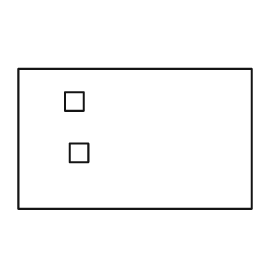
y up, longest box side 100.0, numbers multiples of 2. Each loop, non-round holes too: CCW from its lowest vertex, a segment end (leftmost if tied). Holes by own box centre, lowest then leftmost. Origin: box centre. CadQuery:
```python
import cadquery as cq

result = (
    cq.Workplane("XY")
    .moveTo(-50.0, -30.0)
    .lineTo(50.0, -30.0)
    .lineTo(50.0, 30.0)
    .lineTo(-50.0, 30.0)
    .close()
    .moveTo(-28.0, -10.0)
    .lineTo(-20.0, -10.0)
    .lineTo(-20.0, -2.0)
    .lineTo(-28.0, -2.0)
    .close()
    .moveTo(-30.0, 12.0)
    .lineTo(-22.0, 12.0)
    .lineTo(-22.0, 20.0)
    .lineTo(-30.0, 20.0)
    .close()
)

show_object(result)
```